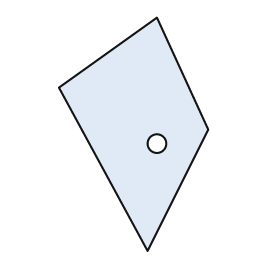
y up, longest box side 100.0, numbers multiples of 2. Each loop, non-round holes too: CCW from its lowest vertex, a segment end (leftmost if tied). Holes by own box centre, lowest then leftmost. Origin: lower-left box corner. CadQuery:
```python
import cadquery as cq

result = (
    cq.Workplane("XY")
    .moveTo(38.0, 0.0)
    .lineTo(64.0, 52.0)
    .lineTo(42.0, 100.0)
    .lineTo(0.0, 70.0)
    .close()
    .moveTo(42.0, 46.0)
    .circle(4.0)
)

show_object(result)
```